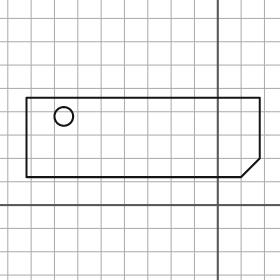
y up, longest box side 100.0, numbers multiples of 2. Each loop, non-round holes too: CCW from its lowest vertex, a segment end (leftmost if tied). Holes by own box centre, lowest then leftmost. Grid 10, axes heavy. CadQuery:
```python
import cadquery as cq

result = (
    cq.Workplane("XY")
    .moveTo(-82.0, 12.0)
    .lineTo(10.0, 12.0)
    .lineTo(18.0, 20.0)
    .lineTo(18.0, 46.0)
    .lineTo(-82.0, 46.0)
    .close()
    .moveTo(-66.0, 38.0)
    .circle(4.0)
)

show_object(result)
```